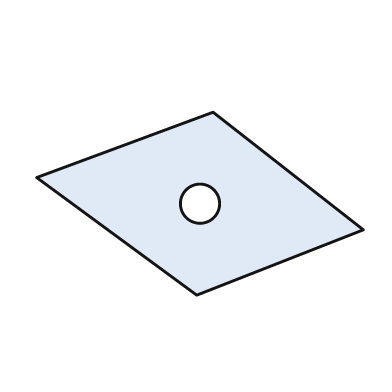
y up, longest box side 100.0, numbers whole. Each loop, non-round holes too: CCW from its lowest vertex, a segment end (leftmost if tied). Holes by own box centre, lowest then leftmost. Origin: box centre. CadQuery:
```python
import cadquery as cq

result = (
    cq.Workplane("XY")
    .moveTo(-1.0, -28.0)
    .lineTo(50.0, -8.0)
    .lineTo(4.0, 28.0)
    .lineTo(-50.0, 8.0)
    .close()
    .moveTo(0.0, 0.0)
    .circle(6.0)
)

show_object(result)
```